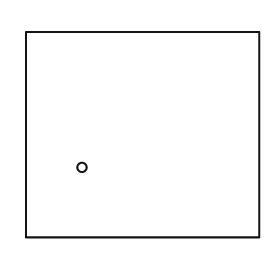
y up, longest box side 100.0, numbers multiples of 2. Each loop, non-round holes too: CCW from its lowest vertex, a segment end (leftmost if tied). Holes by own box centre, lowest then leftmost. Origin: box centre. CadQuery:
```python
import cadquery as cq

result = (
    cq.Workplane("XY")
    .moveTo(-50.0, -44.0)
    .lineTo(50.0, -44.0)
    .lineTo(50.0, 44.0)
    .lineTo(-50.0, 44.0)
    .close()
    .moveTo(-26.0, -14.0)
    .circle(2.0)
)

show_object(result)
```